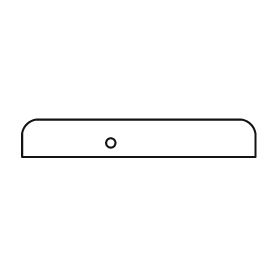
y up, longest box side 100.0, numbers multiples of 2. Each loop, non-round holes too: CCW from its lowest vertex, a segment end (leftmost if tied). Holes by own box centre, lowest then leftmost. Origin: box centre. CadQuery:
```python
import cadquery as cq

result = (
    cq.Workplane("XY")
    .moveTo(-50.0, -8.0)
    .lineTo(50.0, -8.0)
    .lineTo(50.0, 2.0)
    .threePointArc((48.0, 6.0), (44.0, 8.0))
    .lineTo(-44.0, 8.0)
    .threePointArc((-48.0, 6.0), (-50.0, 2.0))
    .close()
    .moveTo(-12.0, -2.0)
    .circle(2.0)
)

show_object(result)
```